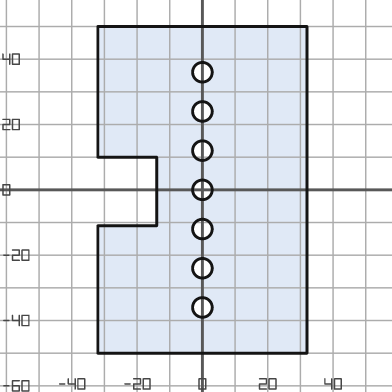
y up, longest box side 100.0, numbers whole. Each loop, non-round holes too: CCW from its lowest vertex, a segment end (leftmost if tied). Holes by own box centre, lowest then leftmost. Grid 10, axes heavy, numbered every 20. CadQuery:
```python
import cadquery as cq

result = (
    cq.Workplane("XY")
    .moveTo(-32.0, -50.0)
    .lineTo(32.0, -50.0)
    .lineTo(32.0, 50.0)
    .lineTo(-32.0, 50.0)
    .lineTo(-32.0, 10.0)
    .lineTo(-14.0, 10.0)
    .lineTo(-14.0, -11.0)
    .lineTo(-32.0, -11.0)
    .close()
    .moveTo(0.0, -36.0)
    .circle(3.0)
    .moveTo(0.0, -24.0)
    .circle(3.0)
    .moveTo(0.0, -12.0)
    .circle(3.0)
    .moveTo(0.0, 0.0)
    .circle(3.0)
    .moveTo(0.0, 12.0)
    .circle(3.0)
    .moveTo(0.0, 24.0)
    .circle(3.0)
    .moveTo(0.0, 36.0)
    .circle(3.0)
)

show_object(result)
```